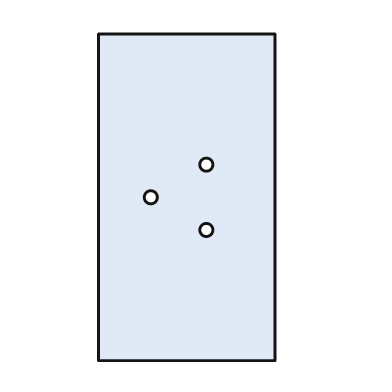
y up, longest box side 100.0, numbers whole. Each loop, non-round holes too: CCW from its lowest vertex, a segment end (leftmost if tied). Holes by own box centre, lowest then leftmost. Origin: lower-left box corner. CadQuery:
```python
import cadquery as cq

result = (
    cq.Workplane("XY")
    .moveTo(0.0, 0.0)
    .lineTo(54.0, 0.0)
    .lineTo(54.0, 100.0)
    .lineTo(0.0, 100.0)
    .close()
    .moveTo(33.0, 40.0)
    .circle(2.0)
    .moveTo(16.0, 50.0)
    .circle(2.0)
    .moveTo(33.0, 60.0)
    .circle(2.0)
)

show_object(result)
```